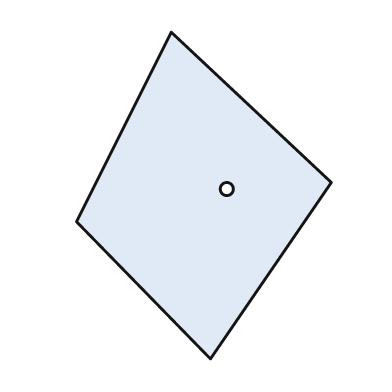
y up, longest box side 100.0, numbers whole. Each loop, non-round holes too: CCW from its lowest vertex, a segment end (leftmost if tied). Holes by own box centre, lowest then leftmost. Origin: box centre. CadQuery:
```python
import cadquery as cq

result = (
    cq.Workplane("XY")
    .moveTo(2.0, -50.0)
    .lineTo(39.0, 4.0)
    .lineTo(-10.0, 50.0)
    .lineTo(-39.0, -8.0)
    .close()
    .moveTo(7.0, 2.0)
    .circle(2.0)
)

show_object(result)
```